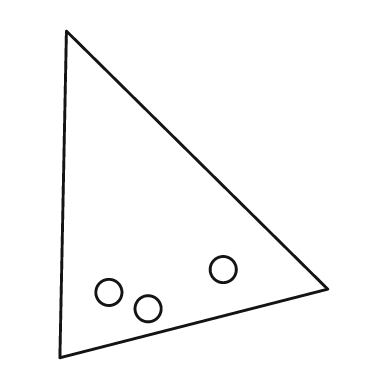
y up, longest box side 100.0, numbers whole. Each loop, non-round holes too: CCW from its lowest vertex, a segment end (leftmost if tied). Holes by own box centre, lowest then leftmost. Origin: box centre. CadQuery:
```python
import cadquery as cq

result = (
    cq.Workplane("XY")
    .moveTo(-41.0, -50.0)
    .lineTo(41.0, -29.0)
    .lineTo(-39.0, 50.0)
    .close()
    .moveTo(-14.0, -35.0)
    .circle(4.0)
    .moveTo(-26.0, -30.0)
    .circle(4.0)
    .moveTo(9.0, -23.0)
    .circle(4.0)
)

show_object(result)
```